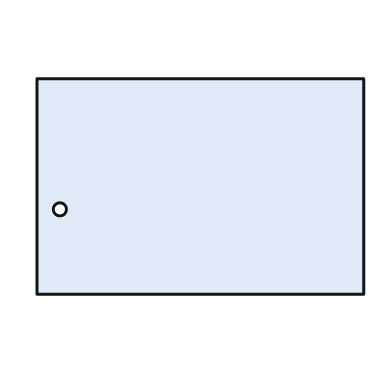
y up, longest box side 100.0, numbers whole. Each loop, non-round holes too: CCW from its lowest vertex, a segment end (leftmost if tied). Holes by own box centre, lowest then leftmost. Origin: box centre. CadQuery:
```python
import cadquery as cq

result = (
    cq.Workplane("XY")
    .moveTo(-50.0, -33.0)
    .lineTo(50.0, -33.0)
    .lineTo(50.0, 33.0)
    .lineTo(-50.0, 33.0)
    .close()
    .moveTo(-43.0, -7.0)
    .circle(2.0)
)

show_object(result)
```